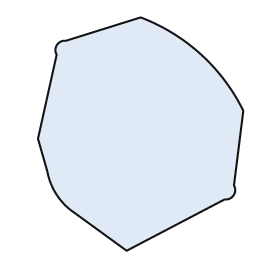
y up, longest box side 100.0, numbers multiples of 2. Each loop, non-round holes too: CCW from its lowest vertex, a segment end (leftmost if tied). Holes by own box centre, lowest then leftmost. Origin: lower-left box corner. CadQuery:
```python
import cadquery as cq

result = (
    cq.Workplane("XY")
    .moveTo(38.0, 0.0)
    .lineTo(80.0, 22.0)
    .threePointArc((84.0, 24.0), (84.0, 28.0))
    .lineTo(88.0, 60.0)
    .threePointArc((70.0, 84.0), (44.0, 100.0))
    .lineTo(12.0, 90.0)
    .threePointArc((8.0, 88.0), (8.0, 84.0))
    .lineTo(0.0, 48.0)
    .lineTo(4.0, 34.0)
    .threePointArc((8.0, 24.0), (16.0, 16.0))
    .close()
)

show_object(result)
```